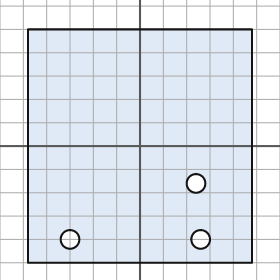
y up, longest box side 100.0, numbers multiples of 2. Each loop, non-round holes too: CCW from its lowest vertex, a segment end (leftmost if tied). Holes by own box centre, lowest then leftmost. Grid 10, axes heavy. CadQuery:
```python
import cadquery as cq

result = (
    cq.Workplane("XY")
    .moveTo(-48.0, -50.0)
    .lineTo(48.0, -50.0)
    .lineTo(48.0, 50.0)
    .lineTo(-48.0, 50.0)
    .close()
    .moveTo(-30.0, -40.0)
    .circle(4.0)
    .moveTo(26.0, -40.0)
    .circle(4.0)
    .moveTo(24.0, -16.0)
    .circle(4.0)
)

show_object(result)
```